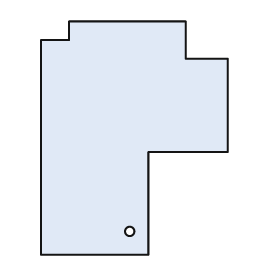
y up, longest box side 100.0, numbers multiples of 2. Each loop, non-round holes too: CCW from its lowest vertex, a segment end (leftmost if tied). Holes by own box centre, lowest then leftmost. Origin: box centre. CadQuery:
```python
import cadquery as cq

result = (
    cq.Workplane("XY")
    .moveTo(-40.0, -50.0)
    .lineTo(6.0, -50.0)
    .lineTo(6.0, -6.0)
    .lineTo(40.0, -6.0)
    .lineTo(40.0, 34.0)
    .lineTo(22.0, 34.0)
    .lineTo(22.0, 50.0)
    .lineTo(-28.0, 50.0)
    .lineTo(-28.0, 42.0)
    .lineTo(-40.0, 42.0)
    .close()
    .moveTo(-2.0, -40.0)
    .circle(2.0)
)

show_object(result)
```